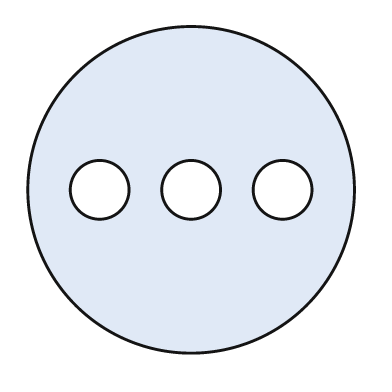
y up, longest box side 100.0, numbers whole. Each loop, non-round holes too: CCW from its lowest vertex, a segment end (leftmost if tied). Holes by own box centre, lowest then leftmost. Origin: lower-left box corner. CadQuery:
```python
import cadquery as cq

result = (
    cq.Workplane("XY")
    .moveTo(50.0, 50.0)
    .circle(50.0)
    .moveTo(22.0, 50.0)
    .circle(9.0)
    .moveTo(50.0, 50.0)
    .circle(9.0)
    .moveTo(78.0, 50.0)
    .circle(9.0)
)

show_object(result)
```